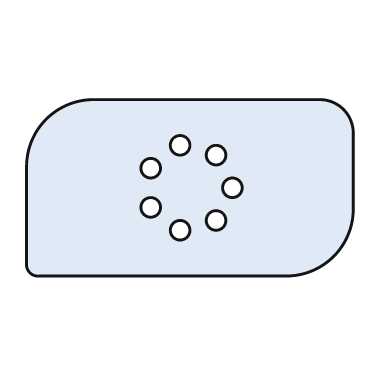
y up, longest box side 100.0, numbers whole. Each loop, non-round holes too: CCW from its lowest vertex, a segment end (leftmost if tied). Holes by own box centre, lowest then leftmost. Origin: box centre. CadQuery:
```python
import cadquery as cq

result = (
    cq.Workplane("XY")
    .moveTo(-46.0, -27.0)
    .lineTo(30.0, -27.0)
    .threePointArc((44.0, -21.0), (50.0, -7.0))
    .lineTo(50.0, 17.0)
    .threePointArc((47.0, 24.0), (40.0, 27.0))
    .lineTo(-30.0, 27.0)
    .threePointArc((-44.0, 21.0), (-50.0, 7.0))
    .lineTo(-50.0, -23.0)
    .threePointArc((-49.0, -26.0), (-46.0, -27.0))
    .close()
    .moveTo(-3.0, -13.0)
    .circle(3.0)
    .moveTo(8.0, -10.0)
    .circle(3.0)
    .moveTo(-12.0, -6.0)
    .circle(3.0)
    .moveTo(13.0, 0.0)
    .circle(3.0)
    .moveTo(-12.0, 6.0)
    .circle(3.0)
    .moveTo(8.0, 10.0)
    .circle(3.0)
    .moveTo(-3.0, 13.0)
    .circle(3.0)
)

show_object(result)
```